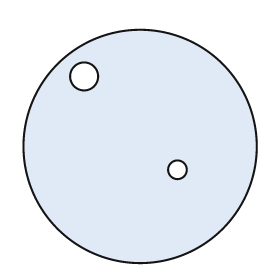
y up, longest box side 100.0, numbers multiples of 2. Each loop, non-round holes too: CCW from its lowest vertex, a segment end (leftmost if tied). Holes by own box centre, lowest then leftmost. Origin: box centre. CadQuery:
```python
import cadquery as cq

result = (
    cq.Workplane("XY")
    .moveTo(0.0, 0.0)
    .circle(50.0)
    .moveTo(16.0, -10.0)
    .circle(4.0)
    .moveTo(-24.0, 30.0)
    .circle(6.0)
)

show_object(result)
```